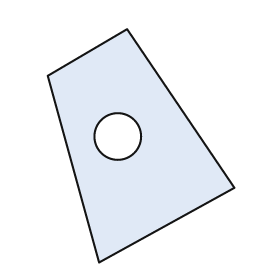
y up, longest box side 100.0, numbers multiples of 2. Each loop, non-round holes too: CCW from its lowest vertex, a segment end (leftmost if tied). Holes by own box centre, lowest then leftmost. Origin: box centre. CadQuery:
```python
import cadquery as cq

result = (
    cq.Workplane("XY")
    .moveTo(-18.0, -50.0)
    .lineTo(40.0, -18.0)
    .lineTo(-6.0, 50.0)
    .lineTo(-40.0, 30.0)
    .close()
    .moveTo(-10.0, 4.0)
    .circle(10.0)
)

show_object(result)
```